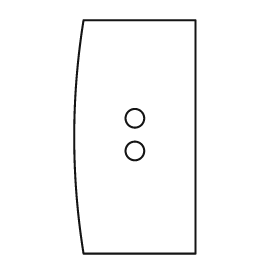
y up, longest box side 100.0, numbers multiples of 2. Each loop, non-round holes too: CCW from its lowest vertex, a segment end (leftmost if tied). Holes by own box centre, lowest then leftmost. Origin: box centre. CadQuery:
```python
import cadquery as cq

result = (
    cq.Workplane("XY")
    .moveTo(-22.0, -50.0)
    .lineTo(26.0, -50.0)
    .lineTo(26.0, 50.0)
    .lineTo(-22.0, 50.0)
    .threePointArc((-26.0, 0.0), (-22.0, -50.0))
    .close()
    .moveTo(0.0, -6.0)
    .circle(4.0)
    .moveTo(0.0, 8.0)
    .circle(4.0)
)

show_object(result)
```